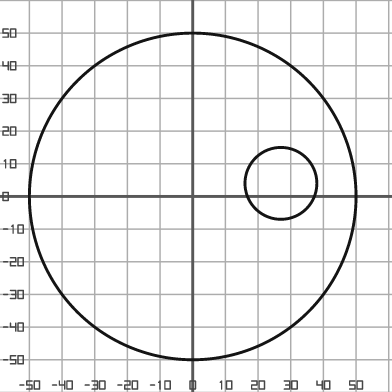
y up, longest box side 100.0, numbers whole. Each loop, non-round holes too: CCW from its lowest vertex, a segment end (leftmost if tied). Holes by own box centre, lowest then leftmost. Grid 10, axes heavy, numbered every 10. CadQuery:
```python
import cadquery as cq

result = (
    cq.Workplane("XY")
    .moveTo(0.0, 0.0)
    .circle(50.0)
    .moveTo(27.0, 4.0)
    .circle(11.0)
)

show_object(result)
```